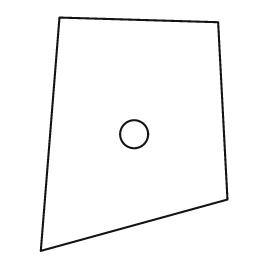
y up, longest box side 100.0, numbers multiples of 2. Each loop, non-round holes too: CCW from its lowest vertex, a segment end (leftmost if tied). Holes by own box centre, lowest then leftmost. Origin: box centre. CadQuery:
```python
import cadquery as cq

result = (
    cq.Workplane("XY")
    .moveTo(-40.0, -50.0)
    .lineTo(40.0, -28.0)
    .lineTo(36.0, 48.0)
    .lineTo(-32.0, 50.0)
    .close()
    .moveTo(0.0, 0.0)
    .circle(6.0)
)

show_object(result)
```